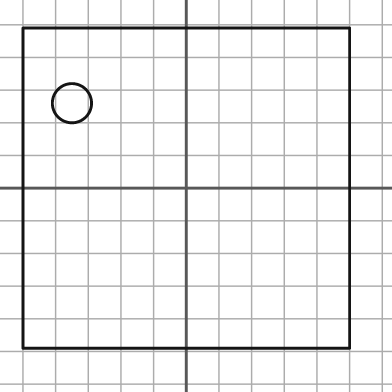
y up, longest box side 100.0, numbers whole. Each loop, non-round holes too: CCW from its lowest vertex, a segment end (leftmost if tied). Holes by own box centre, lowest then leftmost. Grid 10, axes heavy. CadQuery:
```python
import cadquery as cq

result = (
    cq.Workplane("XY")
    .moveTo(-50.0, -49.0)
    .lineTo(50.0, -49.0)
    .lineTo(50.0, 49.0)
    .lineTo(-50.0, 49.0)
    .close()
    .moveTo(-35.0, 26.0)
    .circle(6.0)
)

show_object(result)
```